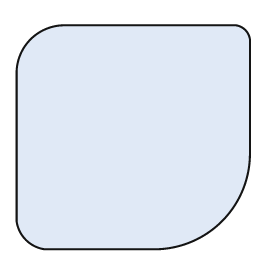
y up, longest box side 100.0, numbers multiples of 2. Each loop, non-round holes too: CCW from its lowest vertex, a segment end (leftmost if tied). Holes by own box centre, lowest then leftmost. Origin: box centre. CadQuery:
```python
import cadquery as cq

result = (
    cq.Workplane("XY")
    .moveTo(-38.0, -48.0)
    .lineTo(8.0, -48.0)
    .threePointArc((38.0, -36.0), (50.0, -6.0))
    .lineTo(50.0, 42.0)
    .threePointArc((48.0, 46.0), (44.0, 48.0))
    .lineTo(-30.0, 48.0)
    .threePointArc((-44.0, 42.0), (-50.0, 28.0))
    .lineTo(-50.0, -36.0)
    .threePointArc((-46.0, -44.0), (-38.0, -48.0))
    .close()
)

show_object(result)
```